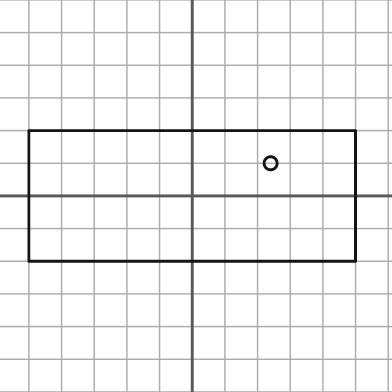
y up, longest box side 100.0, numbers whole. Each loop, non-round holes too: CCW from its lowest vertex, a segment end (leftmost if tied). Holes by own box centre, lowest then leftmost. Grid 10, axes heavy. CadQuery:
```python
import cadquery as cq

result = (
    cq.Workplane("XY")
    .moveTo(-50.0, -20.0)
    .lineTo(50.0, -20.0)
    .lineTo(50.0, 20.0)
    .lineTo(-50.0, 20.0)
    .close()
    .moveTo(24.0, 10.0)
    .circle(2.0)
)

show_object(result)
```